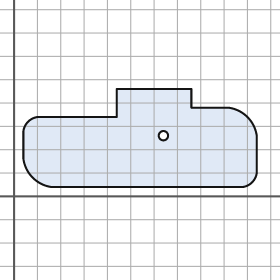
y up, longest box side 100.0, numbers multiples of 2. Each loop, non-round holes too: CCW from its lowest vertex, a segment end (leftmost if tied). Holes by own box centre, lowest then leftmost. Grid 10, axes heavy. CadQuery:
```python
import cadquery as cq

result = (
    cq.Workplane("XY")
    .moveTo(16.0, 4.0)
    .lineTo(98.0, 4.0)
    .threePointArc((102.0, 6.0), (104.0, 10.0))
    .lineTo(104.0, 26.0)
    .threePointArc((100.0, 34.0), (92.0, 38.0))
    .lineTo(76.0, 38.0)
    .lineTo(76.0, 46.0)
    .lineTo(44.0, 46.0)
    .lineTo(44.0, 34.0)
    .lineTo(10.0, 34.0)
    .threePointArc((6.0, 32.0), (4.0, 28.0))
    .lineTo(4.0, 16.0)
    .threePointArc((8.0, 8.0), (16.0, 4.0))
    .close()
    .moveTo(64.0, 26.0)
    .circle(2.0)
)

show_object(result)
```